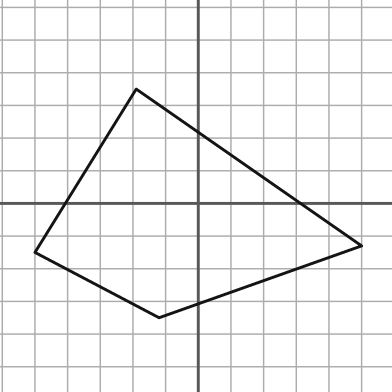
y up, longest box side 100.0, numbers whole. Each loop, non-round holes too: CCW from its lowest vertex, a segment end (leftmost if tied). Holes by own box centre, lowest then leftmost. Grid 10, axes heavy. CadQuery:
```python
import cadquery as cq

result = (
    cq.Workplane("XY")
    .moveTo(-12.0, -35.0)
    .lineTo(50.0, -13.0)
    .lineTo(-19.0, 35.0)
    .lineTo(-50.0, -15.0)
    .close()
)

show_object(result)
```